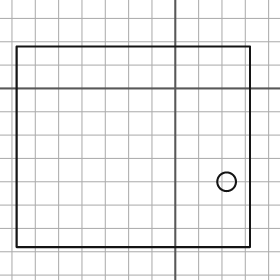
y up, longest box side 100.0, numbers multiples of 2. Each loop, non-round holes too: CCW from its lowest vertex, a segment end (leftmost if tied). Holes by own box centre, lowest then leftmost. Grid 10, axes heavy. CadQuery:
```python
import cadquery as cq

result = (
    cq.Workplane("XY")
    .moveTo(-68.0, -68.0)
    .lineTo(32.0, -68.0)
    .lineTo(32.0, 18.0)
    .lineTo(-68.0, 18.0)
    .close()
    .moveTo(22.0, -40.0)
    .circle(4.0)
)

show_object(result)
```